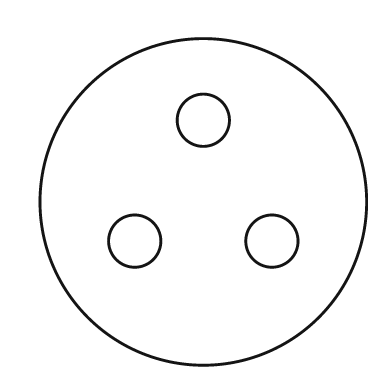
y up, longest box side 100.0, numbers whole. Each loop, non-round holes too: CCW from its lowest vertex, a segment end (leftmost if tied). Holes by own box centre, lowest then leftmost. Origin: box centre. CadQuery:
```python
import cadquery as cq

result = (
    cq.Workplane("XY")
    .moveTo(0.0, 0.0)
    .circle(50.0)
    .moveTo(-21.0, -12.0)
    .circle(8.0)
    .moveTo(21.0, -12.0)
    .circle(8.0)
    .moveTo(0.0, 25.0)
    .circle(8.0)
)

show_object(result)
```